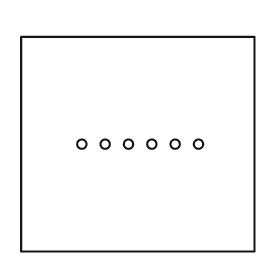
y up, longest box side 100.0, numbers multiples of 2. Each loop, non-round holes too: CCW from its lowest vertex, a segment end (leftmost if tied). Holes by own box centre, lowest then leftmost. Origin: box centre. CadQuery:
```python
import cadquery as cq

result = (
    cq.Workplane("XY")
    .moveTo(-50.0, -46.0)
    .lineTo(50.0, -46.0)
    .lineTo(50.0, 46.0)
    .lineTo(-50.0, 46.0)
    .close()
    .moveTo(-24.0, 0.0)
    .circle(2.0)
    .moveTo(-14.0, 0.0)
    .circle(2.0)
    .moveTo(-4.0, 0.0)
    .circle(2.0)
    .moveTo(6.0, 0.0)
    .circle(2.0)
    .moveTo(16.0, 0.0)
    .circle(2.0)
    .moveTo(26.0, 0.0)
    .circle(2.0)
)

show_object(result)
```